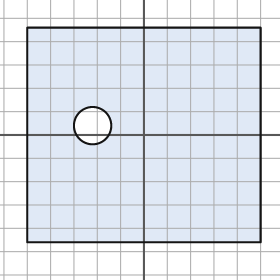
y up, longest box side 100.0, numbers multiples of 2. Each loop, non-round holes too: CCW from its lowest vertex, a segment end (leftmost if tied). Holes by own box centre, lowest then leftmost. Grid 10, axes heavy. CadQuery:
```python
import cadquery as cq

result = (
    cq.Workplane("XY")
    .moveTo(-50.0, -46.0)
    .lineTo(50.0, -46.0)
    .lineTo(50.0, 46.0)
    .lineTo(-50.0, 46.0)
    .close()
    .moveTo(-22.0, 4.0)
    .circle(8.0)
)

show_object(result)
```